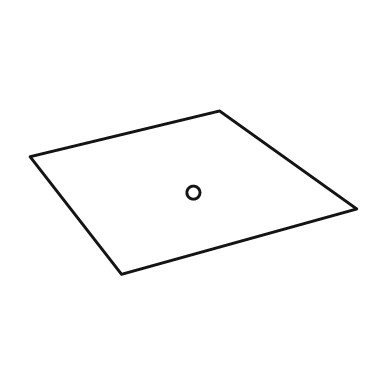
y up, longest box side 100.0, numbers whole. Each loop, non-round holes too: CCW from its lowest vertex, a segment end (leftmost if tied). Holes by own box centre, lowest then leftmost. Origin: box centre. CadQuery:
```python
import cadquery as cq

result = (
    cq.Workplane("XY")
    .moveTo(-22.0, -25.0)
    .lineTo(50.0, -5.0)
    .lineTo(8.0, 25.0)
    .lineTo(-50.0, 11.0)
    .close()
    .moveTo(0.0, 0.0)
    .circle(2.0)
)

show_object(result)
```